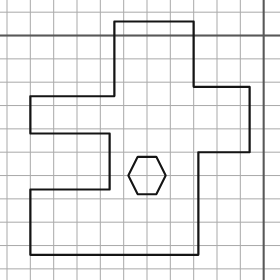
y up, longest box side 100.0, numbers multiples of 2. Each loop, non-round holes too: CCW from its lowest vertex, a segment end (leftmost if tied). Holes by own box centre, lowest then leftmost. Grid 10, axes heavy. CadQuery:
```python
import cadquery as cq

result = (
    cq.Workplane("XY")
    .moveTo(-100.0, -94.0)
    .lineTo(-28.0, -94.0)
    .lineTo(-28.0, -50.0)
    .lineTo(-6.0, -50.0)
    .lineTo(-6.0, -22.0)
    .lineTo(-30.0, -22.0)
    .lineTo(-30.0, 6.0)
    .lineTo(-64.0, 6.0)
    .lineTo(-64.0, -26.0)
    .lineTo(-100.0, -26.0)
    .lineTo(-100.0, -42.0)
    .lineTo(-66.0, -42.0)
    .lineTo(-66.0, -66.0)
    .lineTo(-100.0, -66.0)
    .close()
    .moveTo(-54.0, -68.0)
    .lineTo(-46.0, -68.0)
    .lineTo(-42.0, -60.0)
    .lineTo(-46.0, -52.0)
    .lineTo(-54.0, -52.0)
    .lineTo(-58.0, -60.0)
    .close()
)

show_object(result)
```